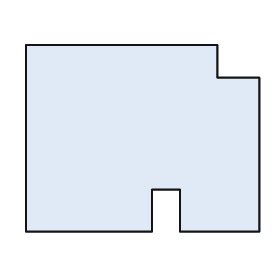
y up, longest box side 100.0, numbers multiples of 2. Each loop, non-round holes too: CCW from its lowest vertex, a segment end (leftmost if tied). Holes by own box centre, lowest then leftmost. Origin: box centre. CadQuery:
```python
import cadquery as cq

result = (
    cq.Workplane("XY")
    .moveTo(-50.0, -40.0)
    .lineTo(4.0, -40.0)
    .lineTo(4.0, -22.0)
    .lineTo(16.0, -22.0)
    .lineTo(16.0, -40.0)
    .lineTo(50.0, -40.0)
    .lineTo(50.0, 26.0)
    .lineTo(32.0, 26.0)
    .lineTo(32.0, 40.0)
    .lineTo(-50.0, 40.0)
    .close()
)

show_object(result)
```